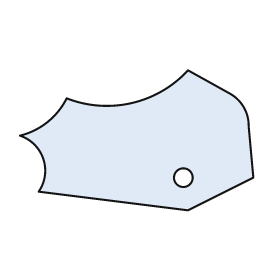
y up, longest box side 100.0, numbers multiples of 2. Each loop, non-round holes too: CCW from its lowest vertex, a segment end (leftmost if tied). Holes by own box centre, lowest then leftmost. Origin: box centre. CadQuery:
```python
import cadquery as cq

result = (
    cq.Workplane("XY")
    .moveTo(22.0, -30.0)
    .lineTo(50.0, -16.0)
    .lineTo(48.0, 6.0)
    .threePointArc((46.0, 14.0), (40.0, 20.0))
    .lineTo(22.0, 30.0)
    .threePointArc((-2.0, 16.0), (-30.0, 18.0))
    .threePointArc((-38.0, 8.0), (-50.0, 2.0))
    .threePointArc((-40.0, -8.0), (-42.0, -22.0))
    .close()
    .moveTo(20.0, -16.0)
    .circle(4.0)
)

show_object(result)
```